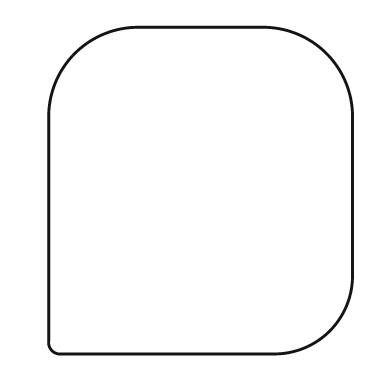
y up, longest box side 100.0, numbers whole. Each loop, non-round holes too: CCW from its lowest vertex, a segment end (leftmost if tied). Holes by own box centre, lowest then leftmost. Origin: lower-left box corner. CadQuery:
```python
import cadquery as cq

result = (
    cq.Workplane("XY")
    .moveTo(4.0, 0.0)
    .lineTo(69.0, 0.0)
    .threePointArc((86.0, 7.0), (93.0, 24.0))
    .lineTo(93.0, 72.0)
    .threePointArc((85.0, 92.0), (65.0, 100.0))
    .lineTo(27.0, 100.0)
    .threePointArc((8.0, 92.0), (0.0, 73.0))
    .lineTo(0.0, 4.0)
    .threePointArc((1.0, 1.0), (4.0, 0.0))
    .close()
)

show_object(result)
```